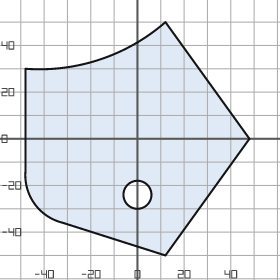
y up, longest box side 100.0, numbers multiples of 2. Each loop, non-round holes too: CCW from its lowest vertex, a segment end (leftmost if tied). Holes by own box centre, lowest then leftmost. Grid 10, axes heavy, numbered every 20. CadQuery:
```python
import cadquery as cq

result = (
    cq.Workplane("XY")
    .moveTo(12.0, -50.0)
    .lineTo(48.0, 0.0)
    .lineTo(12.0, 50.0)
    .threePointArc((-16.0, 34.0), (-48.0, 30.0))
    .lineTo(-48.0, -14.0)
    .threePointArc((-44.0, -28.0), (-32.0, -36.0))
    .close()
    .moveTo(0.0, -24.0)
    .circle(6.0)
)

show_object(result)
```